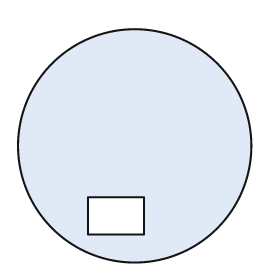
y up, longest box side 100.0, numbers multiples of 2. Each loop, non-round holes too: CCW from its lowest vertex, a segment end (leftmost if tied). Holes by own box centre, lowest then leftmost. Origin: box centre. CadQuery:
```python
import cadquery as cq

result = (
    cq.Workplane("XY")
    .moveTo(0.0, 0.0)
    .circle(50.0)
    .moveTo(-20.0, -38.0)
    .lineTo(4.0, -38.0)
    .lineTo(4.0, -22.0)
    .lineTo(-20.0, -22.0)
    .close()
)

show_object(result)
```